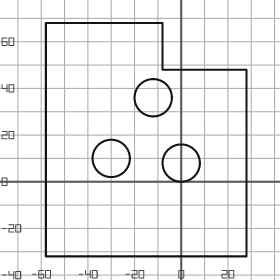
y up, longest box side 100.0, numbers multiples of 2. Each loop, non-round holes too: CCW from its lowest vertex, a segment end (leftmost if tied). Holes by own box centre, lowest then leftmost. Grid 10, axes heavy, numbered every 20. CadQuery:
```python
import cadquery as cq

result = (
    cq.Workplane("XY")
    .moveTo(-58.0, -32.0)
    .lineTo(28.0, -32.0)
    .lineTo(28.0, 48.0)
    .lineTo(-8.0, 48.0)
    .lineTo(-8.0, 68.0)
    .lineTo(-58.0, 68.0)
    .close()
    .moveTo(0.0, 8.0)
    .circle(8.0)
    .moveTo(-30.0, 10.0)
    .circle(8.0)
    .moveTo(-12.0, 36.0)
    .circle(8.0)
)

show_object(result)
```